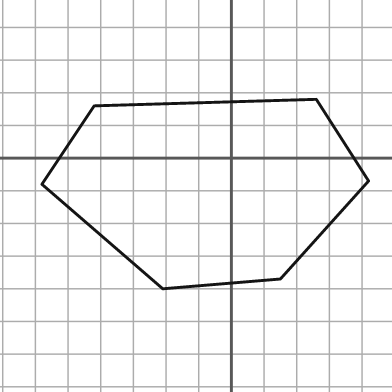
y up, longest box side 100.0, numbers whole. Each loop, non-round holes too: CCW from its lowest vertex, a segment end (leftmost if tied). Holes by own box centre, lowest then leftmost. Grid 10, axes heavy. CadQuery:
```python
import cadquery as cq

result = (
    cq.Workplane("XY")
    .moveTo(-21.0, -40.0)
    .lineTo(15.0, -37.0)
    .lineTo(42.0, -7.0)
    .lineTo(26.0, 18.0)
    .lineTo(-42.0, 16.0)
    .lineTo(-58.0, -8.0)
    .close()
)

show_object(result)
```